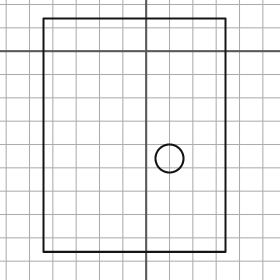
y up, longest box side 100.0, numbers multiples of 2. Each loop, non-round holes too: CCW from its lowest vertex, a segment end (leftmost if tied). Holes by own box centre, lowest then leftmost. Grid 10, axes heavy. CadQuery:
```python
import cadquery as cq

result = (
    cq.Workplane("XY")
    .moveTo(-44.0, -86.0)
    .lineTo(34.0, -86.0)
    .lineTo(34.0, 14.0)
    .lineTo(-44.0, 14.0)
    .close()
    .moveTo(10.0, -46.0)
    .circle(6.0)
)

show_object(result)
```